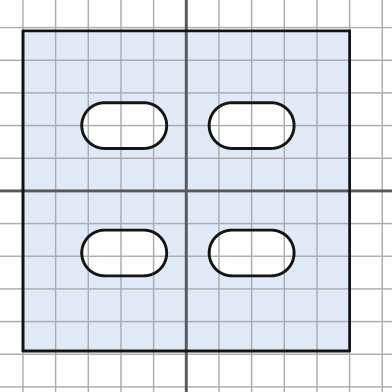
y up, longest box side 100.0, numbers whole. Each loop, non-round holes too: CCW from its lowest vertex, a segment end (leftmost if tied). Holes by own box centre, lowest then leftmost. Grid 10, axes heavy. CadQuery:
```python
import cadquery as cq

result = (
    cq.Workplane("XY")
    .moveTo(-50.0, -49.0)
    .lineTo(50.0, -49.0)
    .lineTo(50.0, 49.0)
    .lineTo(-50.0, 49.0)
    .close()
    .moveTo(-25.0, -26.0)
    .lineTo(-13.0, -26.0)
    .threePointArc((-6.0, -19.0), (-13.0, -12.0))
    .lineTo(-25.0, -12.0)
    .threePointArc((-32.0, -19.0), (-25.0, -26.0))
    .close()
    .moveTo(14.0, -26.0)
    .lineTo(26.0, -26.0)
    .threePointArc((33.0, -19.0), (26.0, -12.0))
    .lineTo(14.0, -12.0)
    .threePointArc((7.0, -19.0), (14.0, -26.0))
    .close()
    .moveTo(-25.0, 13.0)
    .lineTo(-13.0, 13.0)
    .threePointArc((-6.0, 20.0), (-13.0, 27.0))
    .lineTo(-25.0, 27.0)
    .threePointArc((-32.0, 20.0), (-25.0, 13.0))
    .close()
    .moveTo(14.0, 13.0)
    .lineTo(26.0, 13.0)
    .threePointArc((33.0, 20.0), (26.0, 27.0))
    .lineTo(14.0, 27.0)
    .threePointArc((7.0, 20.0), (14.0, 13.0))
    .close()
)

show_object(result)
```